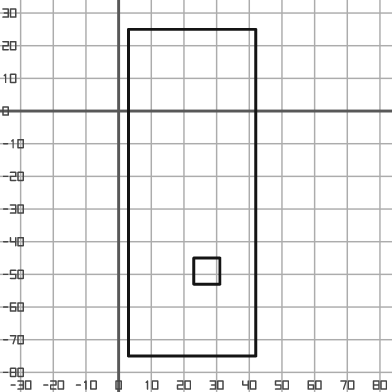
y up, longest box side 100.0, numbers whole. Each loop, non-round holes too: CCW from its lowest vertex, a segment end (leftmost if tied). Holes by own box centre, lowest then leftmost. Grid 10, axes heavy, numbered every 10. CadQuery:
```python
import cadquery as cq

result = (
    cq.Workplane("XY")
    .moveTo(3.0, -75.0)
    .lineTo(42.0, -75.0)
    .lineTo(42.0, 25.0)
    .lineTo(3.0, 25.0)
    .close()
    .moveTo(23.0, -53.0)
    .lineTo(31.0, -53.0)
    .lineTo(31.0, -45.0)
    .lineTo(23.0, -45.0)
    .close()
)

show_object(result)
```